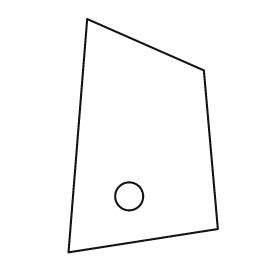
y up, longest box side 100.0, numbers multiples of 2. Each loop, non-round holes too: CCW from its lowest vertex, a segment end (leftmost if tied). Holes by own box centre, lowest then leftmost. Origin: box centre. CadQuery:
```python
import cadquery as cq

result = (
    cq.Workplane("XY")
    .moveTo(-32.0, -50.0)
    .lineTo(32.0, -40.0)
    .lineTo(26.0, 28.0)
    .lineTo(-24.0, 50.0)
    .close()
    .moveTo(-6.0, -26.0)
    .circle(6.0)
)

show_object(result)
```